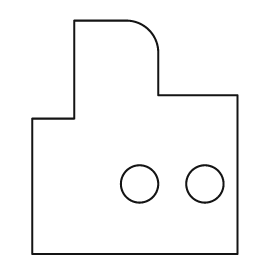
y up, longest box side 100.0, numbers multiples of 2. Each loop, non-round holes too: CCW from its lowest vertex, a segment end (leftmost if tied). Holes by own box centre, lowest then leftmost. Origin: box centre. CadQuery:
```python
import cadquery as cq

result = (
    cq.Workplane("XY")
    .moveTo(-44.0, -50.0)
    .lineTo(44.0, -50.0)
    .lineTo(44.0, 18.0)
    .lineTo(10.0, 18.0)
    .lineTo(10.0, 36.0)
    .threePointArc((6.0, 46.0), (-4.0, 50.0))
    .lineTo(-26.0, 50.0)
    .lineTo(-26.0, 8.0)
    .lineTo(-44.0, 8.0)
    .close()
    .moveTo(2.0, -20.0)
    .circle(8.0)
    .moveTo(30.0, -20.0)
    .circle(8.0)
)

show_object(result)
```